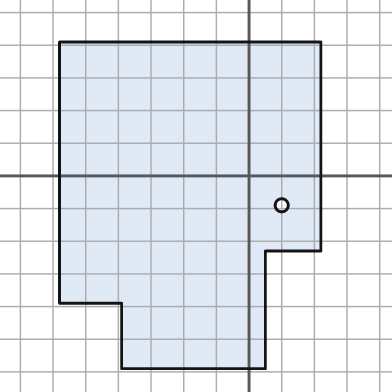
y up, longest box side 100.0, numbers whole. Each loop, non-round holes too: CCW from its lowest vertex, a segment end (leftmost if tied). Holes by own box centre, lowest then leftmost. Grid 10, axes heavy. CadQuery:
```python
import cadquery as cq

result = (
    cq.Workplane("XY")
    .moveTo(-39.0, -59.0)
    .lineTo(5.0, -59.0)
    .lineTo(5.0, -23.0)
    .lineTo(22.0, -23.0)
    .lineTo(22.0, 41.0)
    .lineTo(-58.0, 41.0)
    .lineTo(-58.0, -39.0)
    .lineTo(-39.0, -39.0)
    .close()
    .moveTo(10.0, -9.0)
    .circle(2.0)
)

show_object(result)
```